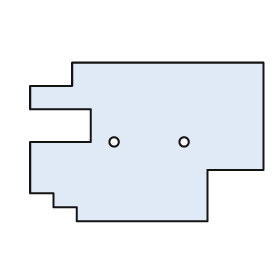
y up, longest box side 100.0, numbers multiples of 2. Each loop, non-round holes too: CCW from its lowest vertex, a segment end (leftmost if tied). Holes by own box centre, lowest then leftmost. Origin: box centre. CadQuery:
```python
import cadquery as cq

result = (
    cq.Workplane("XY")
    .moveTo(-30.0, -34.0)
    .lineTo(26.0, -34.0)
    .lineTo(26.0, -12.0)
    .lineTo(50.0, -12.0)
    .lineTo(50.0, 34.0)
    .lineTo(-32.0, 34.0)
    .lineTo(-32.0, 24.0)
    .lineTo(-50.0, 24.0)
    .lineTo(-50.0, 14.0)
    .lineTo(-24.0, 14.0)
    .lineTo(-24.0, 0.0)
    .lineTo(-50.0, 0.0)
    .lineTo(-50.0, -22.0)
    .lineTo(-40.0, -22.0)
    .lineTo(-40.0, -28.0)
    .lineTo(-30.0, -28.0)
    .close()
    .moveTo(-14.0, 0.0)
    .circle(2.0)
    .moveTo(16.0, 0.0)
    .circle(2.0)
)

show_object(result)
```